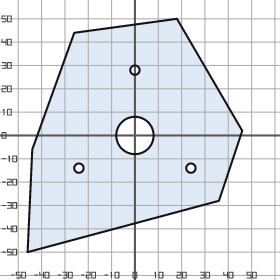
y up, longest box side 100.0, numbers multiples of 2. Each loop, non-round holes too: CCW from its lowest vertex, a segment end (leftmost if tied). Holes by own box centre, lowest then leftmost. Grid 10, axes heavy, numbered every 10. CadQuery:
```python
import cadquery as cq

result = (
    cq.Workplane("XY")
    .moveTo(-46.0, -50.0)
    .lineTo(36.0, -28.0)
    .lineTo(46.0, 2.0)
    .lineTo(18.0, 50.0)
    .lineTo(-26.0, 44.0)
    .lineTo(-44.0, -6.0)
    .close()
    .moveTo(-24.0, -14.0)
    .circle(2.0)
    .moveTo(24.0, -14.0)
    .circle(2.0)
    .moveTo(0.0, 0.0)
    .circle(8.0)
    .moveTo(0.0, 28.0)
    .circle(2.0)
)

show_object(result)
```